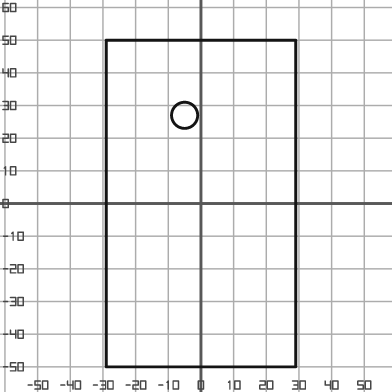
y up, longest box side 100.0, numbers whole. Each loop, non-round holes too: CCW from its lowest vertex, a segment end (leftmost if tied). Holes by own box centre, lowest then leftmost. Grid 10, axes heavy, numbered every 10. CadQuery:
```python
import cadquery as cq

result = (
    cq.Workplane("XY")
    .moveTo(-29.0, -50.0)
    .lineTo(29.0, -50.0)
    .lineTo(29.0, 50.0)
    .lineTo(-29.0, 50.0)
    .close()
    .moveTo(-5.0, 27.0)
    .circle(4.0)
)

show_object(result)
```